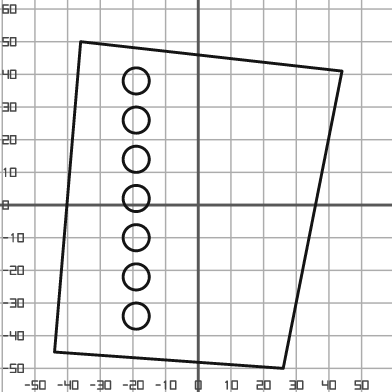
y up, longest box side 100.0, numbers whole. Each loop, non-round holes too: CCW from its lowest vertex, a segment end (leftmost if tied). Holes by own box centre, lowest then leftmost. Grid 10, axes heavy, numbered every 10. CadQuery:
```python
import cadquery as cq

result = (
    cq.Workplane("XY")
    .moveTo(26.0, -50.0)
    .lineTo(44.0, 41.0)
    .lineTo(-36.0, 50.0)
    .lineTo(-44.0, -45.0)
    .close()
    .moveTo(-19.0, -34.0)
    .circle(4.0)
    .moveTo(-19.0, -22.0)
    .circle(4.0)
    .moveTo(-19.0, -10.0)
    .circle(4.0)
    .moveTo(-19.0, 2.0)
    .circle(4.0)
    .moveTo(-19.0, 14.0)
    .circle(4.0)
    .moveTo(-19.0, 26.0)
    .circle(4.0)
    .moveTo(-19.0, 38.0)
    .circle(4.0)
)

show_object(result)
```